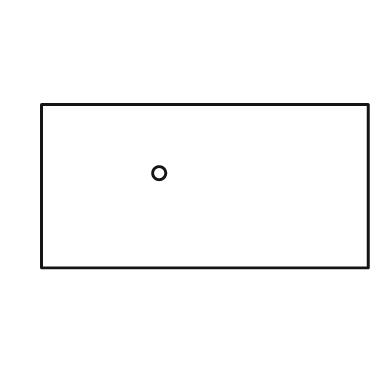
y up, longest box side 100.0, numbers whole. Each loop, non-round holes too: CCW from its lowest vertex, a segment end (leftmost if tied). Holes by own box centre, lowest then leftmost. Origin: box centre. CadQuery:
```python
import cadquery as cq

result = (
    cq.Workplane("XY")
    .moveTo(-50.0, -25.0)
    .lineTo(50.0, -25.0)
    .lineTo(50.0, 25.0)
    .lineTo(-50.0, 25.0)
    .close()
    .moveTo(-14.0, 4.0)
    .circle(2.0)
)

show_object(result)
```